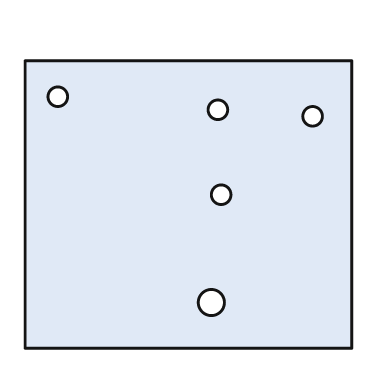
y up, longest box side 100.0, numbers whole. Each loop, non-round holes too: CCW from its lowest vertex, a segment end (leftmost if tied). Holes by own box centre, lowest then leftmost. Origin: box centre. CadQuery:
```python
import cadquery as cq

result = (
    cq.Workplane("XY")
    .moveTo(-50.0, -44.0)
    .lineTo(50.0, -44.0)
    .lineTo(50.0, 44.0)
    .lineTo(-50.0, 44.0)
    .close()
    .moveTo(7.0, -30.0)
    .circle(4.0)
    .moveTo(10.0, 3.0)
    .circle(3.0)
    .moveTo(38.0, 27.0)
    .circle(3.0)
    .moveTo(9.0, 29.0)
    .circle(3.0)
    .moveTo(-40.0, 33.0)
    .circle(3.0)
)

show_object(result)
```